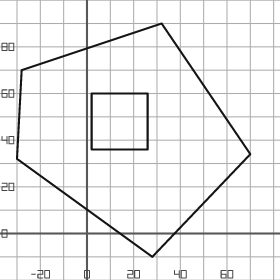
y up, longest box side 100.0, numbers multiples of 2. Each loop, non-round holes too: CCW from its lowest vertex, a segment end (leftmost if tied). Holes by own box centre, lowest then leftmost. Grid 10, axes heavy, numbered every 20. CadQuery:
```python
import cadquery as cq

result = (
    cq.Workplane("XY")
    .moveTo(28.0, -10.0)
    .lineTo(70.0, 34.0)
    .lineTo(32.0, 90.0)
    .lineTo(-28.0, 70.0)
    .lineTo(-30.0, 32.0)
    .close()
    .moveTo(2.0, 36.0)
    .lineTo(26.0, 36.0)
    .lineTo(26.0, 60.0)
    .lineTo(2.0, 60.0)
    .close()
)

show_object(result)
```